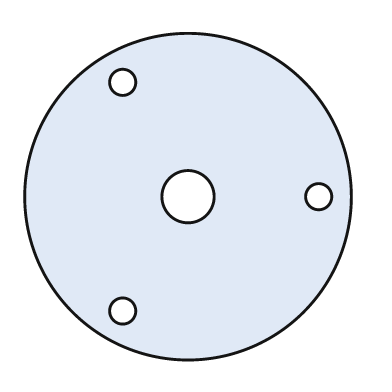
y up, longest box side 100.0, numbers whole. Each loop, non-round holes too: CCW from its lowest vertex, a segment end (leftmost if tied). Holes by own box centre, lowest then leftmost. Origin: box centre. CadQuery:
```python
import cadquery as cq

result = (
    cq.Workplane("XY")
    .moveTo(0.0, 0.0)
    .circle(50.0)
    .moveTo(-20.0, -35.0)
    .circle(4.0)
    .moveTo(0.0, 0.0)
    .circle(8.0)
    .moveTo(40.0, 0.0)
    .circle(4.0)
    .moveTo(-20.0, 35.0)
    .circle(4.0)
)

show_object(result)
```